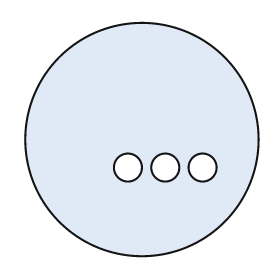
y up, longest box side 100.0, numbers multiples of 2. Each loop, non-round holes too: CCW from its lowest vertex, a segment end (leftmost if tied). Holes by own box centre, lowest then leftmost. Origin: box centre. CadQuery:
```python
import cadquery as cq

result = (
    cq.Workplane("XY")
    .moveTo(0.0, 0.0)
    .circle(50.0)
    .moveTo(-6.0, -12.0)
    .circle(6.0)
    .moveTo(10.0, -12.0)
    .circle(6.0)
    .moveTo(26.0, -12.0)
    .circle(6.0)
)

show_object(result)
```